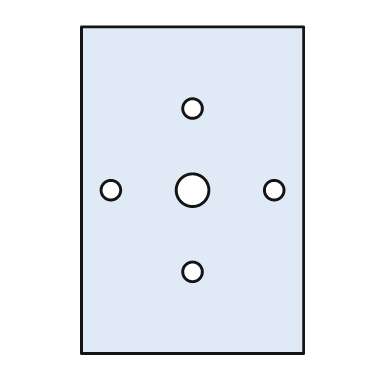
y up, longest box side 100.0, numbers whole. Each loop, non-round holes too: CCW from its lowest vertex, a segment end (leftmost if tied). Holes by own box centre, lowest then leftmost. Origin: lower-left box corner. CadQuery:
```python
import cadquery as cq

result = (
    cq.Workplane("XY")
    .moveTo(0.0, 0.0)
    .lineTo(68.0, 0.0)
    .lineTo(68.0, 100.0)
    .lineTo(0.0, 100.0)
    .close()
    .moveTo(34.0, 25.0)
    .circle(3.0)
    .moveTo(9.0, 50.0)
    .circle(3.0)
    .moveTo(34.0, 50.0)
    .circle(5.0)
    .moveTo(59.0, 50.0)
    .circle(3.0)
    .moveTo(34.0, 75.0)
    .circle(3.0)
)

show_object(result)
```